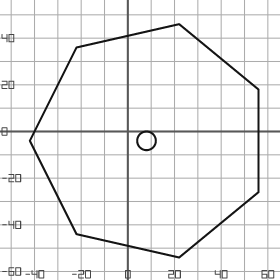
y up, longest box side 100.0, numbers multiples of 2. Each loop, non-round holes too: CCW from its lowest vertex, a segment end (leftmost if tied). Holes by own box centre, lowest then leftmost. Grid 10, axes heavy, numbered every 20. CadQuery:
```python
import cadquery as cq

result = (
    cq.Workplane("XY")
    .moveTo(22.0, -54.0)
    .lineTo(56.0, -26.0)
    .lineTo(56.0, 18.0)
    .lineTo(22.0, 46.0)
    .lineTo(-22.0, 36.0)
    .lineTo(-42.0, -4.0)
    .lineTo(-22.0, -44.0)
    .close()
    .moveTo(8.0, -4.0)
    .circle(4.0)
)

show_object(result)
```